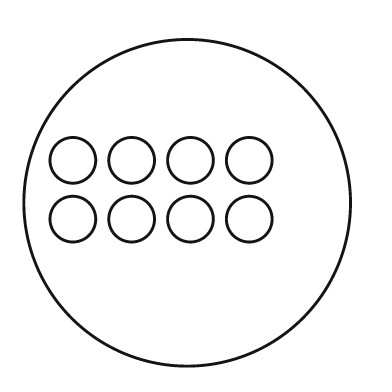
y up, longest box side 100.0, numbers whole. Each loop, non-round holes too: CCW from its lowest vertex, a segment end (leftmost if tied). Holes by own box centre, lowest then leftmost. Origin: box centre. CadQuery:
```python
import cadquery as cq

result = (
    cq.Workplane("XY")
    .moveTo(0.0, 0.0)
    .circle(50.0)
    .moveTo(-35.0, -5.0)
    .circle(7.0)
    .moveTo(-17.0, -5.0)
    .circle(7.0)
    .moveTo(1.0, -5.0)
    .circle(7.0)
    .moveTo(19.0, -5.0)
    .circle(7.0)
    .moveTo(-35.0, 13.0)
    .circle(7.0)
    .moveTo(-17.0, 13.0)
    .circle(7.0)
    .moveTo(1.0, 13.0)
    .circle(7.0)
    .moveTo(19.0, 13.0)
    .circle(7.0)
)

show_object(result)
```